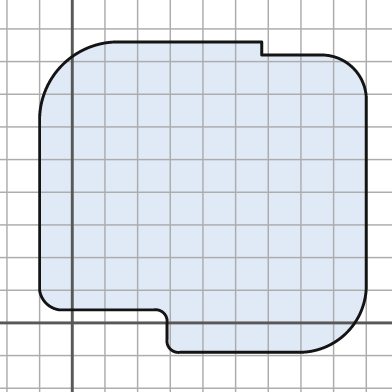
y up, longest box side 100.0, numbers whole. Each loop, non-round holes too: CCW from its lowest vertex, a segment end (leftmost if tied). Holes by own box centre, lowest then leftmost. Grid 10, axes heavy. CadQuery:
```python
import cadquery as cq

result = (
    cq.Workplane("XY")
    .moveTo(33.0, -9.0)
    .lineTo(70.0, -9.0)
    .threePointArc((84.0, -3.0), (90.0, 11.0))
    .lineTo(90.0, 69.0)
    .threePointArc((86.0, 78.0), (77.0, 82.0))
    .lineTo(58.0, 82.0)
    .lineTo(58.0, 86.0)
    .lineTo(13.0, 86.0)
    .threePointArc((-3.0, 79.0), (-10.0, 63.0))
    .lineTo(-10.0, 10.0)
    .threePointArc((-8.0, 6.0), (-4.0, 4.0))
    .lineTo(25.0, 4.0)
    .threePointArc((28.0, 3.0), (29.0, 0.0))
    .lineTo(29.0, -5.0)
    .threePointArc((30.0, -8.0), (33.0, -9.0))
    .close()
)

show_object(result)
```